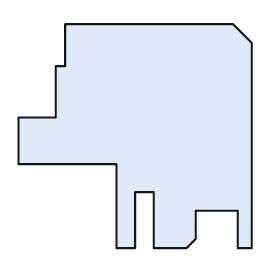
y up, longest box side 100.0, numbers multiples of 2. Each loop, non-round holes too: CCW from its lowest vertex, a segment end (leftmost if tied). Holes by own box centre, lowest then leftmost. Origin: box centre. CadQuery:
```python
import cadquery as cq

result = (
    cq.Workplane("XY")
    .moveTo(-8.0, -48.0)
    .lineTo(0.0, -48.0)
    .lineTo(0.0, -24.0)
    .lineTo(8.0, -24.0)
    .lineTo(8.0, -48.0)
    .lineTo(22.0, -48.0)
    .lineTo(26.0, -44.0)
    .lineTo(26.0, -32.0)
    .lineTo(44.0, -32.0)
    .lineTo(44.0, -48.0)
    .lineTo(50.0, -48.0)
    .lineTo(50.0, 40.0)
    .lineTo(42.0, 48.0)
    .lineTo(-30.0, 48.0)
    .lineTo(-30.0, 30.0)
    .lineTo(-34.0, 30.0)
    .lineTo(-34.0, 8.0)
    .lineTo(-50.0, 8.0)
    .lineTo(-50.0, -12.0)
    .lineTo(-8.0, -12.0)
    .close()
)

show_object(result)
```